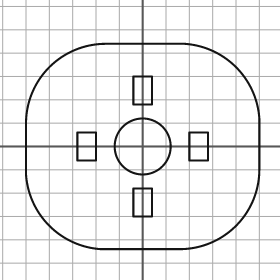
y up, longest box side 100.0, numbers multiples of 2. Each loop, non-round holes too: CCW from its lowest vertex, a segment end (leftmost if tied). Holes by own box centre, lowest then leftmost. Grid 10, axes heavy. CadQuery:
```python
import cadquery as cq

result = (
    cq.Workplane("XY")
    .moveTo(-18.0, -44.0)
    .lineTo(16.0, -44.0)
    .threePointArc((40.0, -34.0), (50.0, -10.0))
    .lineTo(50.0, 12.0)
    .threePointArc((40.0, 34.0), (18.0, 44.0))
    .lineTo(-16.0, 44.0)
    .threePointArc((-40.0, 34.0), (-50.0, 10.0))
    .lineTo(-50.0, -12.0)
    .threePointArc((-40.0, -34.0), (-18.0, -44.0))
    .close()
    .moveTo(-4.0, -30.0)
    .lineTo(4.0, -30.0)
    .lineTo(4.0, -18.0)
    .lineTo(-4.0, -18.0)
    .close()
    .moveTo(-28.0, -6.0)
    .lineTo(-20.0, -6.0)
    .lineTo(-20.0, 6.0)
    .lineTo(-28.0, 6.0)
    .close()
    .moveTo(0.0, 0.0)
    .circle(12.0)
    .moveTo(20.0, -6.0)
    .lineTo(28.0, -6.0)
    .lineTo(28.0, 6.0)
    .lineTo(20.0, 6.0)
    .close()
    .moveTo(-4.0, 18.0)
    .lineTo(4.0, 18.0)
    .lineTo(4.0, 30.0)
    .lineTo(-4.0, 30.0)
    .close()
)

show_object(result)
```